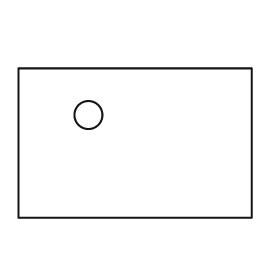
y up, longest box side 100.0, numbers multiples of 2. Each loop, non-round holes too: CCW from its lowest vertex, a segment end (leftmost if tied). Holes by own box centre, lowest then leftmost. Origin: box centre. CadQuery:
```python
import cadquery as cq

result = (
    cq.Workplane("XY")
    .moveTo(-50.0, -32.0)
    .lineTo(50.0, -32.0)
    .lineTo(50.0, 32.0)
    .lineTo(-50.0, 32.0)
    .close()
    .moveTo(-20.0, 12.0)
    .circle(6.0)
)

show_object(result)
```